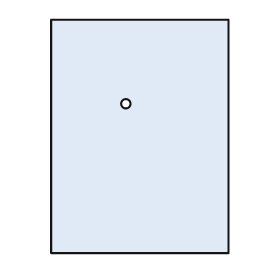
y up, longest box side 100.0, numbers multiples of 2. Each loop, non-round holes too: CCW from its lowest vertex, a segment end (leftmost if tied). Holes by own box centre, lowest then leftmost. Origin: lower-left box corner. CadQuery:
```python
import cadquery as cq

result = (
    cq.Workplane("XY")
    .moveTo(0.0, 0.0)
    .lineTo(76.0, 0.0)
    .lineTo(76.0, 100.0)
    .lineTo(0.0, 100.0)
    .close()
    .moveTo(32.0, 64.0)
    .circle(2.0)
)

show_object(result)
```